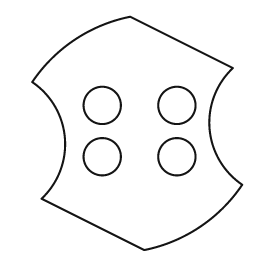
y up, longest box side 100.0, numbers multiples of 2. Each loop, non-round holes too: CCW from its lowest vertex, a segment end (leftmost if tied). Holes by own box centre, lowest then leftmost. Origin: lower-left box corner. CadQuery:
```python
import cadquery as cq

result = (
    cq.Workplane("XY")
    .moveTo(48.0, 0.0)
    .threePointArc((72.0, 10.0), (90.0, 28.0))
    .threePointArc((76.0, 52.0), (86.0, 78.0))
    .lineTo(42.0, 100.0)
    .threePointArc((18.0, 90.0), (0.0, 72.0))
    .threePointArc((14.0, 48.0), (4.0, 22.0))
    .close()
    .moveTo(30.0, 40.0)
    .circle(8.0)
    .moveTo(62.0, 40.0)
    .circle(8.0)
    .moveTo(30.0, 62.0)
    .circle(8.0)
    .moveTo(62.0, 62.0)
    .circle(8.0)
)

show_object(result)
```